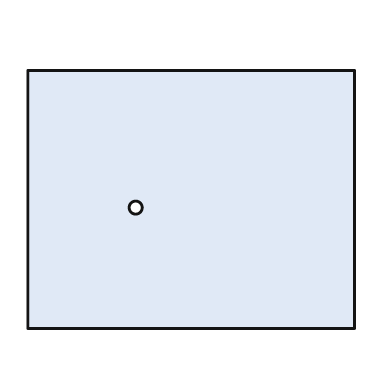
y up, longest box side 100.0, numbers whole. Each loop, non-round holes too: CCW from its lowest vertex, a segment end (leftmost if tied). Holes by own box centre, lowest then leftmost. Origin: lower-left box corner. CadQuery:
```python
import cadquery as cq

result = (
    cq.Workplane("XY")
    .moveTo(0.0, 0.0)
    .lineTo(100.0, 0.0)
    .lineTo(100.0, 79.0)
    .lineTo(0.0, 79.0)
    .close()
    .moveTo(33.0, 37.0)
    .circle(2.0)
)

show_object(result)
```